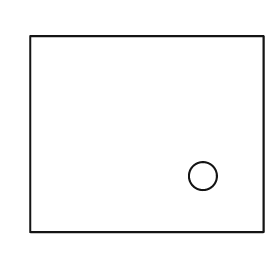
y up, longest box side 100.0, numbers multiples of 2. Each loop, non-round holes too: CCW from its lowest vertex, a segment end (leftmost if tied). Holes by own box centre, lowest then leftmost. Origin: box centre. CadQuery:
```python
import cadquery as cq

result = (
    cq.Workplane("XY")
    .moveTo(-50.0, -42.0)
    .lineTo(50.0, -42.0)
    .lineTo(50.0, 42.0)
    .lineTo(-50.0, 42.0)
    .close()
    .moveTo(24.0, -18.0)
    .circle(6.0)
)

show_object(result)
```